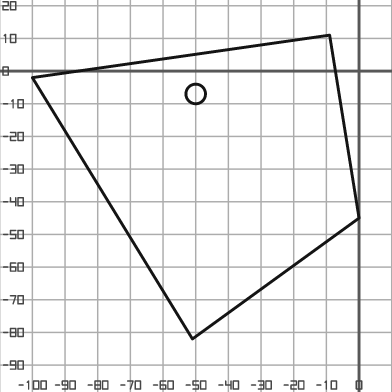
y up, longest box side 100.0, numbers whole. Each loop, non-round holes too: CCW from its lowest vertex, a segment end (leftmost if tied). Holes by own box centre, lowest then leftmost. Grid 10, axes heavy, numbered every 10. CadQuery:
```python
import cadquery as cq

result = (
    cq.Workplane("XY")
    .moveTo(-51.0, -82.0)
    .lineTo(0.0, -45.0)
    .lineTo(-9.0, 11.0)
    .lineTo(-100.0, -2.0)
    .close()
    .moveTo(-50.0, -7.0)
    .circle(3.0)
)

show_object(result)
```